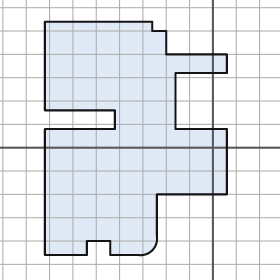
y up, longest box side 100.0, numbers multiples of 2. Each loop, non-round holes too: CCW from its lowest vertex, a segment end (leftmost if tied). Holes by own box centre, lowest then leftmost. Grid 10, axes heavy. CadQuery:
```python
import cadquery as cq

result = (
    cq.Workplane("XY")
    .moveTo(-72.0, -46.0)
    .lineTo(-54.0, -46.0)
    .lineTo(-54.0, -40.0)
    .lineTo(-44.0, -40.0)
    .lineTo(-44.0, -46.0)
    .lineTo(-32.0, -46.0)
    .threePointArc((-26.0, -44.0), (-24.0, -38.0))
    .lineTo(-24.0, -20.0)
    .lineTo(6.0, -20.0)
    .lineTo(6.0, 8.0)
    .lineTo(-16.0, 8.0)
    .lineTo(-16.0, 32.0)
    .lineTo(6.0, 32.0)
    .lineTo(6.0, 40.0)
    .lineTo(-20.0, 40.0)
    .lineTo(-20.0, 50.0)
    .lineTo(-26.0, 50.0)
    .lineTo(-26.0, 54.0)
    .lineTo(-72.0, 54.0)
    .lineTo(-72.0, 16.0)
    .lineTo(-42.0, 16.0)
    .lineTo(-42.0, 8.0)
    .lineTo(-72.0, 8.0)
    .close()
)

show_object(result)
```